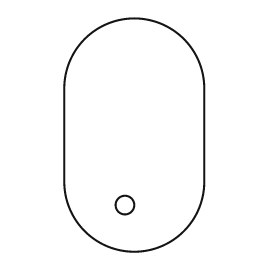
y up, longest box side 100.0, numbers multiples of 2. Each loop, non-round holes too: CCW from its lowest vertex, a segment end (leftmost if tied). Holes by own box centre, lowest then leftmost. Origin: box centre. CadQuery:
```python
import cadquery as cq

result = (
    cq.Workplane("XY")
    .moveTo(-30.0, -20.0)
    .threePointArc((0.0, -50.0), (30.0, -20.0))
    .lineTo(30.0, 20.0)
    .threePointArc((0.0, 50.0), (-30.0, 20.0))
    .close()
    .moveTo(-4.0, -30.0)
    .circle(4.0)
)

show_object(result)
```